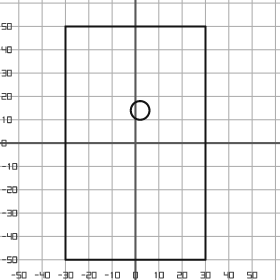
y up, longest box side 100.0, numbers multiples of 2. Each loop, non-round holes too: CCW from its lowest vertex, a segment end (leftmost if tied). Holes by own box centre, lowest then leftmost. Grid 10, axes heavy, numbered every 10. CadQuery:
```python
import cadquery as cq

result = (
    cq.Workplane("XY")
    .moveTo(-30.0, -50.0)
    .lineTo(30.0, -50.0)
    .lineTo(30.0, 50.0)
    .lineTo(-30.0, 50.0)
    .close()
    .moveTo(2.0, 14.0)
    .circle(4.0)
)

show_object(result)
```